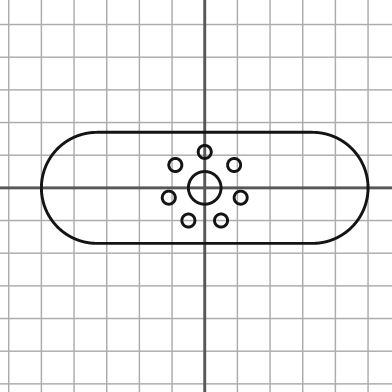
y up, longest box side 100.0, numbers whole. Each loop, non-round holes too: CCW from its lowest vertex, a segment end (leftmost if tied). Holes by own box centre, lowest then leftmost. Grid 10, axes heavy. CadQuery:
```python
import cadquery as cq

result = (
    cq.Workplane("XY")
    .moveTo(-33.0, -17.0)
    .lineTo(33.0, -17.0)
    .threePointArc((50.0, 0.0), (33.0, 17.0))
    .lineTo(-33.0, 17.0)
    .threePointArc((-50.0, 0.0), (-33.0, -17.0))
    .close()
    .moveTo(-5.0, -10.0)
    .circle(2.0)
    .moveTo(5.0, -10.0)
    .circle(2.0)
    .moveTo(-11.0, -3.0)
    .circle(2.0)
    .moveTo(11.0, -3.0)
    .circle(2.0)
    .moveTo(0.0, 0.0)
    .circle(5.0)
    .moveTo(-9.0, 7.0)
    .circle(2.0)
    .moveTo(9.0, 7.0)
    .circle(2.0)
    .moveTo(0.0, 11.0)
    .circle(2.0)
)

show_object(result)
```